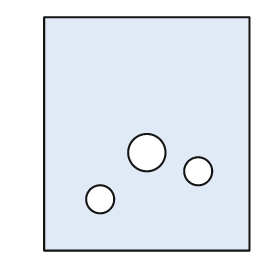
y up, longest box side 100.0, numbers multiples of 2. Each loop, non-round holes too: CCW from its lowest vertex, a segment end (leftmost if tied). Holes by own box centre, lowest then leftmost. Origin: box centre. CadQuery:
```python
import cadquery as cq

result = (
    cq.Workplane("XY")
    .moveTo(-44.0, -50.0)
    .lineTo(44.0, -50.0)
    .lineTo(44.0, 50.0)
    .lineTo(-44.0, 50.0)
    .close()
    .moveTo(-20.0, -28.0)
    .circle(6.0)
    .moveTo(22.0, -16.0)
    .circle(6.0)
    .moveTo(0.0, -8.0)
    .circle(8.0)
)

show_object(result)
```